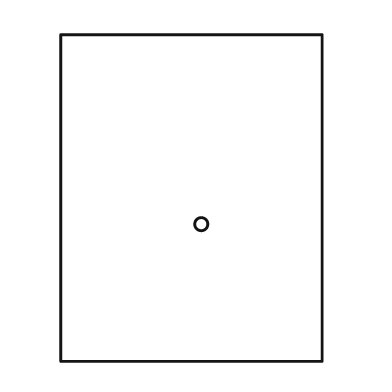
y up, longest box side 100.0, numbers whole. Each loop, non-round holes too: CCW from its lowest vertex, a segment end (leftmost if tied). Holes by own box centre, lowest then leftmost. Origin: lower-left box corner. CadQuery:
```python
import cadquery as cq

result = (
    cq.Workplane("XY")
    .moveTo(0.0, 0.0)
    .lineTo(80.0, 0.0)
    .lineTo(80.0, 100.0)
    .lineTo(0.0, 100.0)
    .close()
    .moveTo(43.0, 42.0)
    .circle(2.0)
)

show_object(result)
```